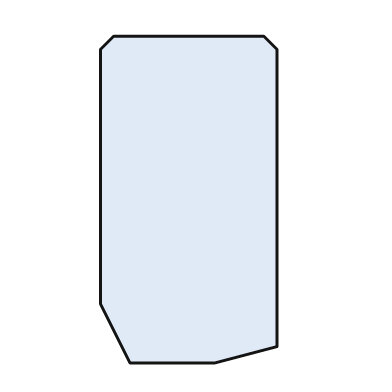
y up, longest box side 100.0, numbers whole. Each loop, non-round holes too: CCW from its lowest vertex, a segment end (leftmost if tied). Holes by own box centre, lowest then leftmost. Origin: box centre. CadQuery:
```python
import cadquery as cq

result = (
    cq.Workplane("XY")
    .moveTo(-18.0, -50.0)
    .lineTo(8.0, -50.0)
    .lineTo(27.0, -45.0)
    .lineTo(27.0, 46.0)
    .lineTo(23.0, 50.0)
    .lineTo(-23.0, 50.0)
    .lineTo(-27.0, 46.0)
    .lineTo(-27.0, -32.0)
    .close()
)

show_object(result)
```